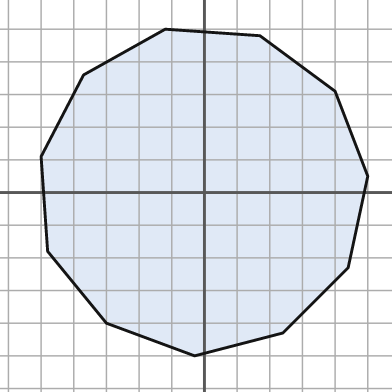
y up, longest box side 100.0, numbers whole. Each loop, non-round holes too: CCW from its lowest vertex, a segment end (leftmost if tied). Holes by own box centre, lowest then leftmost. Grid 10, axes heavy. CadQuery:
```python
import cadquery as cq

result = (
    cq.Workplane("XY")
    .moveTo(-3.0, -50.0)
    .lineTo(24.0, -43.0)
    .lineTo(44.0, -23.0)
    .lineTo(50.0, 5.0)
    .lineTo(40.0, 31.0)
    .lineTo(17.0, 48.0)
    .lineTo(-12.0, 50.0)
    .lineTo(-37.0, 36.0)
    .lineTo(-50.0, 11.0)
    .lineTo(-48.0, -18.0)
    .lineTo(-30.0, -40.0)
    .close()
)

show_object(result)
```